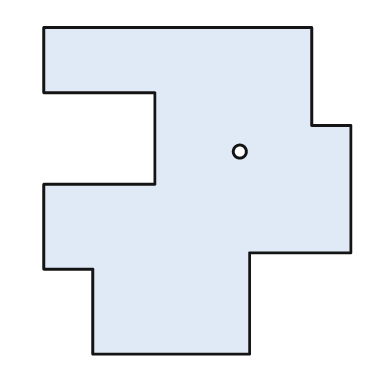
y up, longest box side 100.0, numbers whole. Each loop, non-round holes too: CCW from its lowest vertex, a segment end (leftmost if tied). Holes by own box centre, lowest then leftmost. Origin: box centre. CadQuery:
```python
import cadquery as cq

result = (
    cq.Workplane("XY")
    .moveTo(-32.0, -50.0)
    .lineTo(16.0, -50.0)
    .lineTo(16.0, -19.0)
    .lineTo(47.0, -19.0)
    .lineTo(47.0, 20.0)
    .lineTo(35.0, 20.0)
    .lineTo(35.0, 50.0)
    .lineTo(-47.0, 50.0)
    .lineTo(-47.0, 30.0)
    .lineTo(-13.0, 30.0)
    .lineTo(-13.0, 2.0)
    .lineTo(-47.0, 2.0)
    .lineTo(-47.0, -24.0)
    .lineTo(-32.0, -24.0)
    .close()
    .moveTo(13.0, 12.0)
    .circle(2.0)
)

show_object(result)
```